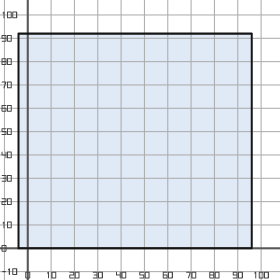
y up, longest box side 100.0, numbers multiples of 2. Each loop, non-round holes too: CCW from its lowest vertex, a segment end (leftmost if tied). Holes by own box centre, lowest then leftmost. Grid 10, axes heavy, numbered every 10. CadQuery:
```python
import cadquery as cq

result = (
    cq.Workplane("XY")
    .moveTo(-4.0, 0.0)
    .lineTo(96.0, 0.0)
    .lineTo(96.0, 92.0)
    .lineTo(-4.0, 92.0)
    .close()
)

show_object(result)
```